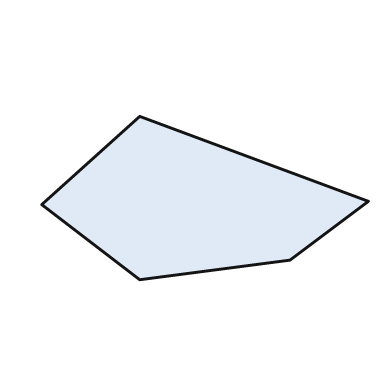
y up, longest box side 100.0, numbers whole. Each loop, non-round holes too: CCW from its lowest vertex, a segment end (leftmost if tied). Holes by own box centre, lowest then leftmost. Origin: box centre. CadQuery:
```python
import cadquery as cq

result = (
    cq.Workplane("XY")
    .moveTo(-20.0, -25.0)
    .lineTo(26.0, -19.0)
    .lineTo(50.0, -1.0)
    .lineTo(-20.0, 25.0)
    .lineTo(-50.0, -2.0)
    .close()
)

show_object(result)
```